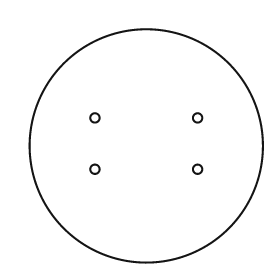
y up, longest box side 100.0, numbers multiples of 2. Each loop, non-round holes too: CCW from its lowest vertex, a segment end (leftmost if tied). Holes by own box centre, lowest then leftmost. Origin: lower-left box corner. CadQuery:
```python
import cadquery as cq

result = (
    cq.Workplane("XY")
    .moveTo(50.0, 50.0)
    .circle(50.0)
    .moveTo(28.0, 40.0)
    .circle(2.0)
    .moveTo(72.0, 40.0)
    .circle(2.0)
    .moveTo(28.0, 62.0)
    .circle(2.0)
    .moveTo(72.0, 62.0)
    .circle(2.0)
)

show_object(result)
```